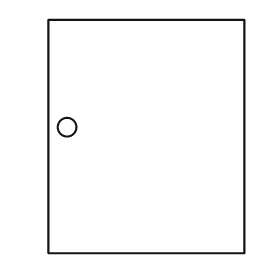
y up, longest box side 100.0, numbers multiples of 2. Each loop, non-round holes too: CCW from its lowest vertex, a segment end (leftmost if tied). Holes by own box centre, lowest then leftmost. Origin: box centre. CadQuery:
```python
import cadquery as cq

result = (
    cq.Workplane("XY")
    .moveTo(-42.0, -50.0)
    .lineTo(42.0, -50.0)
    .lineTo(42.0, 50.0)
    .lineTo(-42.0, 50.0)
    .close()
    .moveTo(-34.0, 4.0)
    .circle(4.0)
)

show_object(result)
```